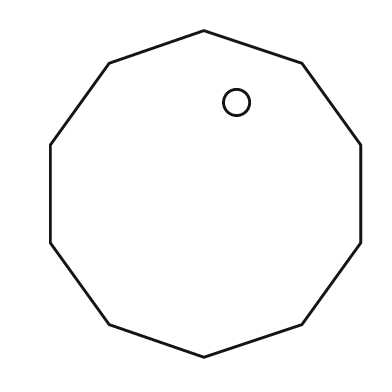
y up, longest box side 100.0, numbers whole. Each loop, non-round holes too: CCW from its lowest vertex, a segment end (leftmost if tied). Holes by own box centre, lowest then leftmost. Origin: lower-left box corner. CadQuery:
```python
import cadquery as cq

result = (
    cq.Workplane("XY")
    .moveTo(47.0, 0.0)
    .lineTo(77.0, 10.0)
    .lineTo(95.0, 35.0)
    .lineTo(95.0, 65.0)
    .lineTo(77.0, 90.0)
    .lineTo(47.0, 100.0)
    .lineTo(18.0, 90.0)
    .lineTo(0.0, 65.0)
    .lineTo(0.0, 35.0)
    .lineTo(18.0, 10.0)
    .close()
    .moveTo(57.0, 78.0)
    .circle(4.0)
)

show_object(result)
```